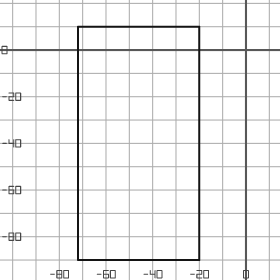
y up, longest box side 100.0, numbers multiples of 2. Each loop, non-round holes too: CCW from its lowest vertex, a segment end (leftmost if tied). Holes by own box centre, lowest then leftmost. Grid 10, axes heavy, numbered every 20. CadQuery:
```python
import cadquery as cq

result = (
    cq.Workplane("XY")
    .moveTo(-72.0, -90.0)
    .lineTo(-20.0, -90.0)
    .lineTo(-20.0, 10.0)
    .lineTo(-72.0, 10.0)
    .close()
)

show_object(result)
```